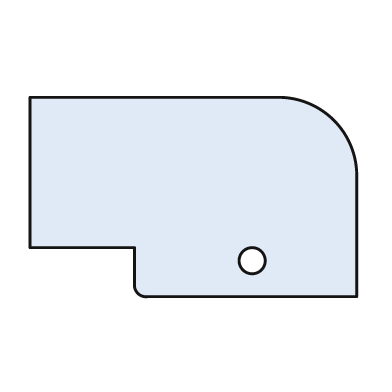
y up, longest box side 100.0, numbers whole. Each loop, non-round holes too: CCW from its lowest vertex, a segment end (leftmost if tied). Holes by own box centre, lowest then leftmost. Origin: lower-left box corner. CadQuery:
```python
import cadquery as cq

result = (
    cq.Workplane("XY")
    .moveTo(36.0, 0.0)
    .lineTo(100.0, 0.0)
    .lineTo(100.0, 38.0)
    .threePointArc((93.0, 54.0), (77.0, 61.0))
    .lineTo(0.0, 61.0)
    .lineTo(0.0, 15.0)
    .lineTo(32.0, 15.0)
    .lineTo(32.0, 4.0)
    .threePointArc((33.0, 1.0), (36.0, 0.0))
    .close()
    .moveTo(68.0, 11.0)
    .circle(4.0)
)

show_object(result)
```